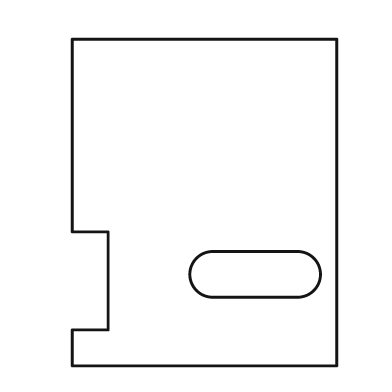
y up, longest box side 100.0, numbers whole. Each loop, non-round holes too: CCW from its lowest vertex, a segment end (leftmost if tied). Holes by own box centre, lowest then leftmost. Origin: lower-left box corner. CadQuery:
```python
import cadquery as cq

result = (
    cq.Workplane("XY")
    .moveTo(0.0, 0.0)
    .lineTo(81.0, 0.0)
    .lineTo(81.0, 100.0)
    .lineTo(0.0, 100.0)
    .lineTo(0.0, 41.0)
    .lineTo(11.0, 41.0)
    .lineTo(11.0, 11.0)
    .lineTo(0.0, 11.0)
    .close()
    .moveTo(43.0, 21.0)
    .lineTo(69.0, 21.0)
    .threePointArc((76.0, 28.0), (69.0, 35.0))
    .lineTo(43.0, 35.0)
    .threePointArc((36.0, 28.0), (43.0, 21.0))
    .close()
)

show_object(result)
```